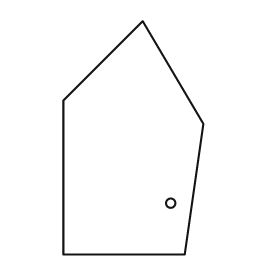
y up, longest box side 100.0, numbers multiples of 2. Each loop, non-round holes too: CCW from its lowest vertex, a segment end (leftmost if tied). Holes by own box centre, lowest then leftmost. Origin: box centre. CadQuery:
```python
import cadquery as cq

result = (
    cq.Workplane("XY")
    .moveTo(-30.0, -50.0)
    .lineTo(22.0, -50.0)
    .lineTo(30.0, 6.0)
    .lineTo(4.0, 50.0)
    .lineTo(-30.0, 16.0)
    .close()
    .moveTo(16.0, -28.0)
    .circle(2.0)
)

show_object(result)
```